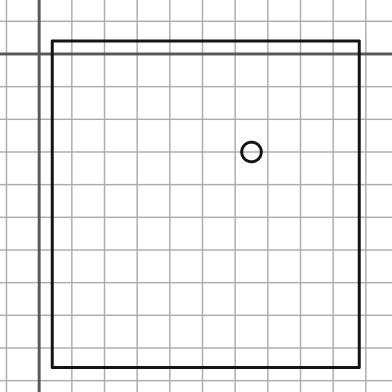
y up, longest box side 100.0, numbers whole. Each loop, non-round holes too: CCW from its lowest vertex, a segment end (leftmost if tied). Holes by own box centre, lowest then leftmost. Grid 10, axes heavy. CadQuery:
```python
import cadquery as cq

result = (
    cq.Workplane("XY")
    .moveTo(4.0, -96.0)
    .lineTo(98.0, -96.0)
    .lineTo(98.0, 4.0)
    .lineTo(4.0, 4.0)
    .close()
    .moveTo(65.0, -30.0)
    .circle(3.0)
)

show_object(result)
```